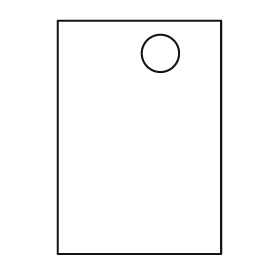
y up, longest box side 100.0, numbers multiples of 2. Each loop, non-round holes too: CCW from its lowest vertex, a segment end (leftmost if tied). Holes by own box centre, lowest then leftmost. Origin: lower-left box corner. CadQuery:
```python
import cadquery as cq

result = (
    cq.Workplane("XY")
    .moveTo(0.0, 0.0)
    .lineTo(70.0, 0.0)
    .lineTo(70.0, 100.0)
    .lineTo(0.0, 100.0)
    .close()
    .moveTo(44.0, 86.0)
    .circle(8.0)
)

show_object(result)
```